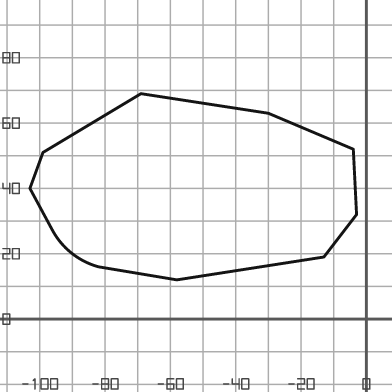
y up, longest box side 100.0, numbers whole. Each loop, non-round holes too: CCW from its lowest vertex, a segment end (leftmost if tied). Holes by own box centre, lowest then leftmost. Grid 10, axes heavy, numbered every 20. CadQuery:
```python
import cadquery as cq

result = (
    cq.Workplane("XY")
    .moveTo(-58.0, 12.0)
    .lineTo(-13.0, 19.0)
    .lineTo(-3.0, 32.0)
    .lineTo(-4.0, 52.0)
    .lineTo(-30.0, 63.0)
    .lineTo(-69.0, 69.0)
    .lineTo(-99.0, 51.0)
    .lineTo(-103.0, 40.0)
    .lineTo(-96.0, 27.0)
    .threePointArc((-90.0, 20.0), (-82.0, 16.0))
    .close()
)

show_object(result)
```